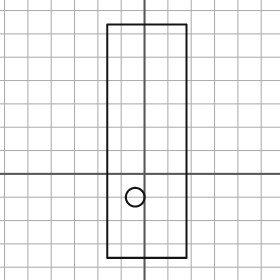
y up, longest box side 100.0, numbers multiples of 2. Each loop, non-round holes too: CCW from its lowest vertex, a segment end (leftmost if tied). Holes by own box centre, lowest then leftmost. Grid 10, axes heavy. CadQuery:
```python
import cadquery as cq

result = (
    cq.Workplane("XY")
    .moveTo(-16.0, -36.0)
    .lineTo(18.0, -36.0)
    .lineTo(18.0, 64.0)
    .lineTo(-16.0, 64.0)
    .close()
    .moveTo(-4.0, -10.0)
    .circle(4.0)
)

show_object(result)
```